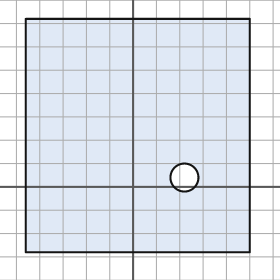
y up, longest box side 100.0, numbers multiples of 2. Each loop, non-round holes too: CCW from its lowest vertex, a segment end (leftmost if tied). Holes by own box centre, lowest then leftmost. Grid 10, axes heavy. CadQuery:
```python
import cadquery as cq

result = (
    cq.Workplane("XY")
    .moveTo(-46.0, -28.0)
    .lineTo(50.0, -28.0)
    .lineTo(50.0, 72.0)
    .lineTo(-46.0, 72.0)
    .close()
    .moveTo(22.0, 4.0)
    .circle(6.0)
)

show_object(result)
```